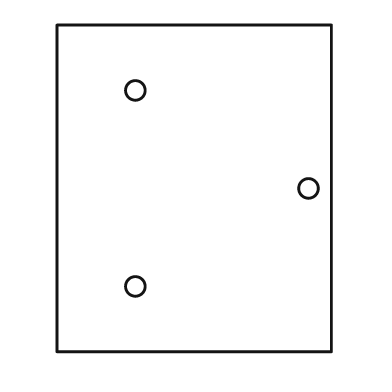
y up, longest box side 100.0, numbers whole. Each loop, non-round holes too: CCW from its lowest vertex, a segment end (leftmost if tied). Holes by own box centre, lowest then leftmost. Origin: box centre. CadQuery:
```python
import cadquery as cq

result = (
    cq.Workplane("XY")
    .moveTo(-42.0, -50.0)
    .lineTo(42.0, -50.0)
    .lineTo(42.0, 50.0)
    .lineTo(-42.0, 50.0)
    .close()
    .moveTo(-18.0, -30.0)
    .circle(3.0)
    .moveTo(35.0, 0.0)
    .circle(3.0)
    .moveTo(-18.0, 30.0)
    .circle(3.0)
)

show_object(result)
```